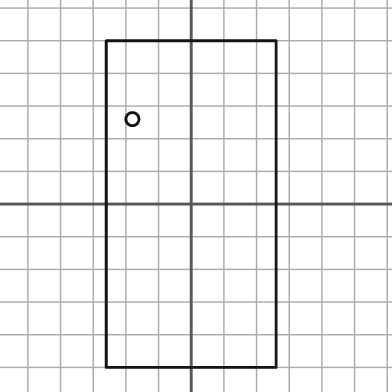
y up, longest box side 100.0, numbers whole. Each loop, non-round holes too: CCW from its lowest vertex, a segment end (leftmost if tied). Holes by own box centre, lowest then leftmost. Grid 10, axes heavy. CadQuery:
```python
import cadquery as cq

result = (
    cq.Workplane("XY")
    .moveTo(-26.0, -50.0)
    .lineTo(26.0, -50.0)
    .lineTo(26.0, 50.0)
    .lineTo(-26.0, 50.0)
    .close()
    .moveTo(-18.0, 26.0)
    .circle(2.0)
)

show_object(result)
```